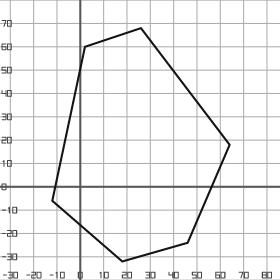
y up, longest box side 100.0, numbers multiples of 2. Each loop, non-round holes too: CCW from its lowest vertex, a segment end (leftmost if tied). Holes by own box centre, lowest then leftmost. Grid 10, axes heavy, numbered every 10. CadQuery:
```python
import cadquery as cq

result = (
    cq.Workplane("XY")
    .moveTo(18.0, -32.0)
    .lineTo(46.0, -24.0)
    .lineTo(64.0, 18.0)
    .lineTo(26.0, 68.0)
    .lineTo(2.0, 60.0)
    .lineTo(-12.0, -6.0)
    .close()
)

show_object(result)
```